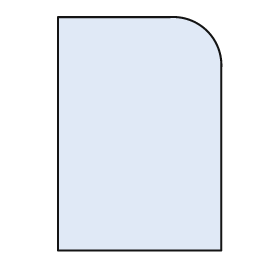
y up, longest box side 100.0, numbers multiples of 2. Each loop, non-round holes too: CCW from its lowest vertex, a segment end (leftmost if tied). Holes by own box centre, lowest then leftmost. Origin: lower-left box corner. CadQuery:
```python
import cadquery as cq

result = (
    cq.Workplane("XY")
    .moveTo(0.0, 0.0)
    .lineTo(70.0, 0.0)
    .lineTo(70.0, 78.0)
    .threePointArc((64.0, 94.0), (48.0, 100.0))
    .lineTo(0.0, 100.0)
    .close()
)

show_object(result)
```